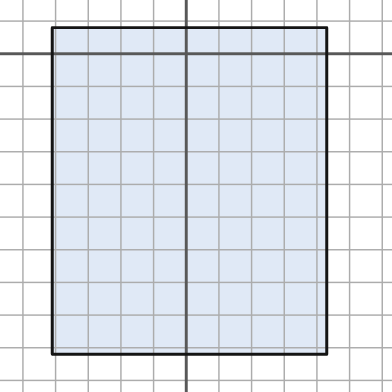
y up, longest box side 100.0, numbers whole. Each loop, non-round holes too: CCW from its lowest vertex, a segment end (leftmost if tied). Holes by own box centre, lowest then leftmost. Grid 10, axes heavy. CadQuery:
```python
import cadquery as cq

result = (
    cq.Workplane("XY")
    .moveTo(-41.0, -92.0)
    .lineTo(43.0, -92.0)
    .lineTo(43.0, 8.0)
    .lineTo(-41.0, 8.0)
    .close()
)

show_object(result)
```